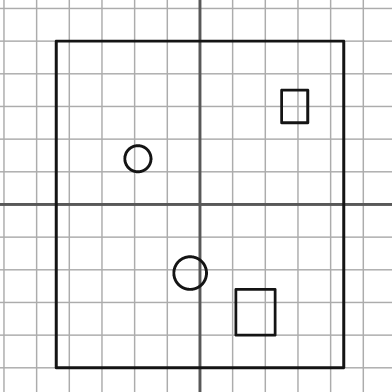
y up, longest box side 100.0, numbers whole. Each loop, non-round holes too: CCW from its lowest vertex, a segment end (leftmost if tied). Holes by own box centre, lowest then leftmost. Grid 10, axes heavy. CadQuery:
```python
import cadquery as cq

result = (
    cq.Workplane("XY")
    .moveTo(-44.0, -50.0)
    .lineTo(44.0, -50.0)
    .lineTo(44.0, 50.0)
    .lineTo(-44.0, 50.0)
    .close()
    .moveTo(11.0, -40.0)
    .lineTo(23.0, -40.0)
    .lineTo(23.0, -26.0)
    .lineTo(11.0, -26.0)
    .close()
    .moveTo(-3.0, -21.0)
    .circle(5.0)
    .moveTo(-19.0, 14.0)
    .circle(4.0)
    .moveTo(25.0, 25.0)
    .lineTo(33.0, 25.0)
    .lineTo(33.0, 35.0)
    .lineTo(25.0, 35.0)
    .close()
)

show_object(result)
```